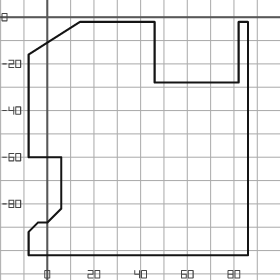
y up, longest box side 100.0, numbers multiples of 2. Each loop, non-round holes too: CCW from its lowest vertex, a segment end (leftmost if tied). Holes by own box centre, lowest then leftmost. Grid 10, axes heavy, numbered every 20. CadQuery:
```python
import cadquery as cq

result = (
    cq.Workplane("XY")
    .moveTo(-8.0, -102.0)
    .lineTo(86.0, -102.0)
    .lineTo(86.0, -2.0)
    .lineTo(82.0, -2.0)
    .lineTo(82.0, -28.0)
    .lineTo(46.0, -28.0)
    .lineTo(46.0, -2.0)
    .lineTo(14.0, -2.0)
    .lineTo(-8.0, -16.0)
    .lineTo(-8.0, -60.0)
    .lineTo(6.0, -60.0)
    .lineTo(6.0, -82.0)
    .lineTo(0.0, -88.0)
    .lineTo(-4.0, -88.0)
    .lineTo(-8.0, -92.0)
    .close()
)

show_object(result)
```